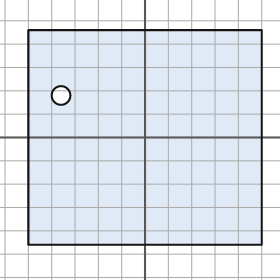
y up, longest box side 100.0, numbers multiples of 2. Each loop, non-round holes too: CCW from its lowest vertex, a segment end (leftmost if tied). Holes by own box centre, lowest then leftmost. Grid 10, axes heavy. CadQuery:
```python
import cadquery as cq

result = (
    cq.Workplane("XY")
    .moveTo(-50.0, -46.0)
    .lineTo(50.0, -46.0)
    .lineTo(50.0, 46.0)
    .lineTo(-50.0, 46.0)
    .close()
    .moveTo(-36.0, 18.0)
    .circle(4.0)
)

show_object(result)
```